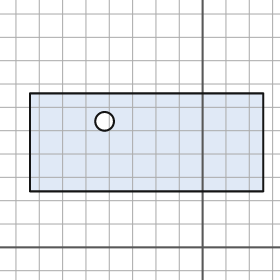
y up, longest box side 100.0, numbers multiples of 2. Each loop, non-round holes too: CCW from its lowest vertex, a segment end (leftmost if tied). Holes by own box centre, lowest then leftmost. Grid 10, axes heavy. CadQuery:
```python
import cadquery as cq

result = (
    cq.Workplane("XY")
    .moveTo(-74.0, 24.0)
    .lineTo(26.0, 24.0)
    .lineTo(26.0, 66.0)
    .lineTo(-74.0, 66.0)
    .close()
    .moveTo(-42.0, 54.0)
    .circle(4.0)
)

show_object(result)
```